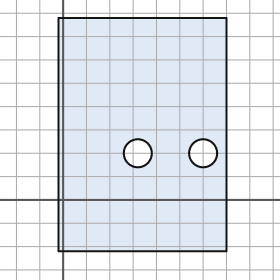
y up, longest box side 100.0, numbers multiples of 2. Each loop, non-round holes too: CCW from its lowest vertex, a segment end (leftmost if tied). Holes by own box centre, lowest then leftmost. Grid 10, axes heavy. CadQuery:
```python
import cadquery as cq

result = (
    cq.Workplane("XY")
    .moveTo(-2.0, -22.0)
    .lineTo(70.0, -22.0)
    .lineTo(70.0, 78.0)
    .lineTo(-2.0, 78.0)
    .close()
    .moveTo(32.0, 20.0)
    .circle(6.0)
    .moveTo(60.0, 20.0)
    .circle(6.0)
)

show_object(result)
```